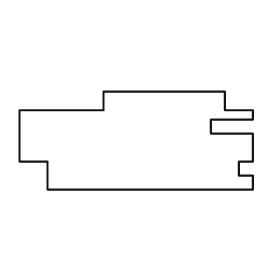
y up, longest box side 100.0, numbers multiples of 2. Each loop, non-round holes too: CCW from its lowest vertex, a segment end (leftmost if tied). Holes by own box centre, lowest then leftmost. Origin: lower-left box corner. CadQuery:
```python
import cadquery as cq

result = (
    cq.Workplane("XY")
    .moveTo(12.0, 0.0)
    .lineTo(100.0, 0.0)
    .lineTo(100.0, 6.0)
    .lineTo(94.0, 6.0)
    .lineTo(94.0, 12.0)
    .lineTo(100.0, 12.0)
    .lineTo(100.0, 24.0)
    .lineTo(82.0, 24.0)
    .lineTo(82.0, 30.0)
    .lineTo(100.0, 30.0)
    .lineTo(100.0, 34.0)
    .lineTo(88.0, 34.0)
    .lineTo(88.0, 42.0)
    .lineTo(36.0, 42.0)
    .lineTo(36.0, 34.0)
    .lineTo(0.0, 34.0)
    .lineTo(0.0, 12.0)
    .lineTo(12.0, 12.0)
    .close()
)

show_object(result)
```